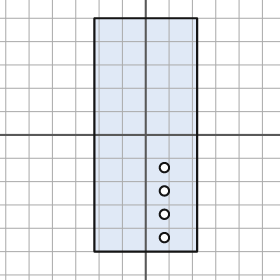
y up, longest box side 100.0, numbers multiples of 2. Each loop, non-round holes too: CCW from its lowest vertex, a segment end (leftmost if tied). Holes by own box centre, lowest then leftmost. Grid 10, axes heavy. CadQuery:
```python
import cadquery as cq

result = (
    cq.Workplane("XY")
    .moveTo(-22.0, -50.0)
    .lineTo(22.0, -50.0)
    .lineTo(22.0, 50.0)
    .lineTo(-22.0, 50.0)
    .close()
    .moveTo(8.0, -44.0)
    .circle(2.0)
    .moveTo(8.0, -34.0)
    .circle(2.0)
    .moveTo(8.0, -24.0)
    .circle(2.0)
    .moveTo(8.0, -14.0)
    .circle(2.0)
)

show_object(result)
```